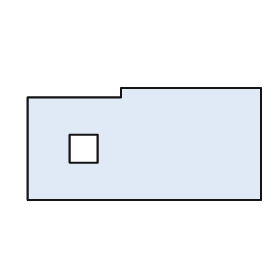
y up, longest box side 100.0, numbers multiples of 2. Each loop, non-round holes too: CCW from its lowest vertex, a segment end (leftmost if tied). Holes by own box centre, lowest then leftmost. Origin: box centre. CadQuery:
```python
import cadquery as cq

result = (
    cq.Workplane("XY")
    .moveTo(-50.0, -24.0)
    .lineTo(50.0, -24.0)
    .lineTo(50.0, 24.0)
    .lineTo(-10.0, 24.0)
    .lineTo(-10.0, 20.0)
    .lineTo(-50.0, 20.0)
    .close()
    .moveTo(-32.0, -8.0)
    .lineTo(-20.0, -8.0)
    .lineTo(-20.0, 4.0)
    .lineTo(-32.0, 4.0)
    .close()
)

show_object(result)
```